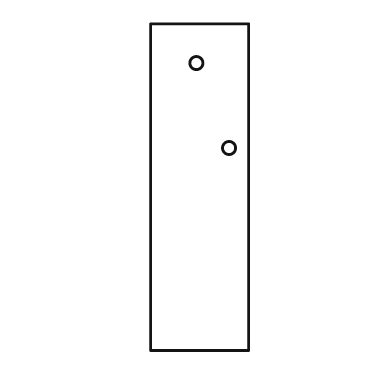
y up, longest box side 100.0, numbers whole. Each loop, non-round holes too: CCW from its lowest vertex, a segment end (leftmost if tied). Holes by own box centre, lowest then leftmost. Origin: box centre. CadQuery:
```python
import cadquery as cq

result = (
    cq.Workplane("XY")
    .moveTo(-15.0, -50.0)
    .lineTo(15.0, -50.0)
    .lineTo(15.0, 50.0)
    .lineTo(-15.0, 50.0)
    .close()
    .moveTo(9.0, 12.0)
    .circle(2.0)
    .moveTo(-1.0, 38.0)
    .circle(2.0)
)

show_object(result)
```